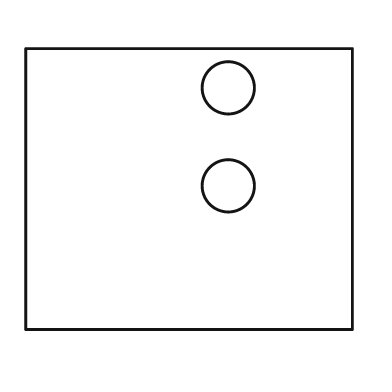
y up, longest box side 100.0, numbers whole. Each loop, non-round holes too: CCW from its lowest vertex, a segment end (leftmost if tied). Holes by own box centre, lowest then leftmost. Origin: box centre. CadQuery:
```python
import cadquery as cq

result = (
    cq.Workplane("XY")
    .moveTo(-50.0, -43.0)
    .lineTo(50.0, -43.0)
    .lineTo(50.0, 43.0)
    .lineTo(-50.0, 43.0)
    .close()
    .moveTo(12.0, 1.0)
    .circle(8.0)
    .moveTo(12.0, 31.0)
    .circle(8.0)
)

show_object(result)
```